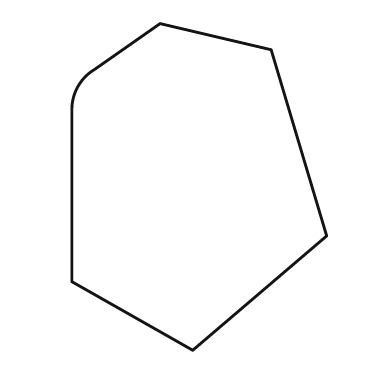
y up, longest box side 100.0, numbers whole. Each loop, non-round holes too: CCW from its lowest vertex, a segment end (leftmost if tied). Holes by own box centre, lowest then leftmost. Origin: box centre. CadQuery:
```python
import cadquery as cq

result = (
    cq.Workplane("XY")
    .moveTo(-2.0, -50.0)
    .lineTo(39.0, -15.0)
    .lineTo(22.0, 42.0)
    .lineTo(-12.0, 50.0)
    .lineTo(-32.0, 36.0)
    .threePointArc((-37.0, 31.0), (-39.0, 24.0))
    .lineTo(-39.0, -29.0)
    .close()
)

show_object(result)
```